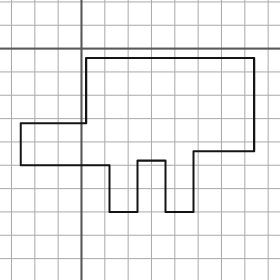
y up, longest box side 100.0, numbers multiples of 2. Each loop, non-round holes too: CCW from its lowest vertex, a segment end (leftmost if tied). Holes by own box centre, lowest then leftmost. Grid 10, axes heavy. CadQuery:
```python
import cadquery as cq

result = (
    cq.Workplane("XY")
    .moveTo(12.0, -70.0)
    .lineTo(24.0, -70.0)
    .lineTo(24.0, -48.0)
    .lineTo(36.0, -48.0)
    .lineTo(36.0, -70.0)
    .lineTo(48.0, -70.0)
    .lineTo(48.0, -44.0)
    .lineTo(74.0, -44.0)
    .lineTo(74.0, -4.0)
    .lineTo(2.0, -4.0)
    .lineTo(2.0, -32.0)
    .lineTo(-26.0, -32.0)
    .lineTo(-26.0, -50.0)
    .lineTo(12.0, -50.0)
    .close()
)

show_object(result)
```